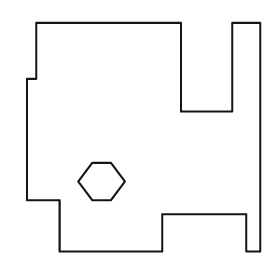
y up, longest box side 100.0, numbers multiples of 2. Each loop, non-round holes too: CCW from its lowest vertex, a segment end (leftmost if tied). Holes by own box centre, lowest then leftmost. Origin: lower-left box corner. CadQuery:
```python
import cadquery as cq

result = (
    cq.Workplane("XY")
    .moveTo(14.0, 0.0)
    .lineTo(58.0, 0.0)
    .lineTo(58.0, 16.0)
    .lineTo(94.0, 16.0)
    .lineTo(94.0, 0.0)
    .lineTo(100.0, 0.0)
    .lineTo(100.0, 98.0)
    .lineTo(88.0, 98.0)
    .lineTo(88.0, 60.0)
    .lineTo(66.0, 60.0)
    .lineTo(66.0, 98.0)
    .lineTo(4.0, 98.0)
    .lineTo(4.0, 74.0)
    .lineTo(0.0, 74.0)
    .lineTo(0.0, 22.0)
    .lineTo(14.0, 22.0)
    .close()
    .moveTo(28.0, 22.0)
    .lineTo(36.0, 22.0)
    .lineTo(42.0, 30.0)
    .lineTo(36.0, 38.0)
    .lineTo(28.0, 38.0)
    .lineTo(22.0, 30.0)
    .close()
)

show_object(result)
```